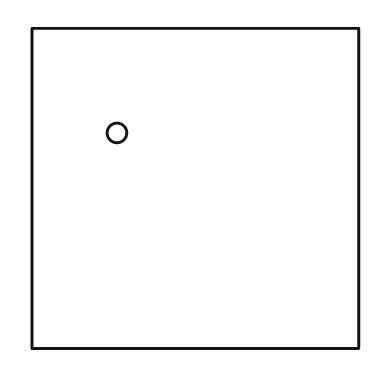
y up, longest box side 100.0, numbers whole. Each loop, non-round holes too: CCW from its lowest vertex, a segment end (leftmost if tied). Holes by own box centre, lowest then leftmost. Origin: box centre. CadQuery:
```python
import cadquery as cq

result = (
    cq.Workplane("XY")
    .moveTo(-50.0, -49.0)
    .lineTo(50.0, -49.0)
    .lineTo(50.0, 49.0)
    .lineTo(-50.0, 49.0)
    .close()
    .moveTo(-24.0, 17.0)
    .circle(3.0)
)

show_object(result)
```